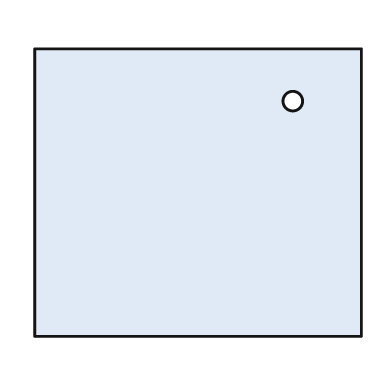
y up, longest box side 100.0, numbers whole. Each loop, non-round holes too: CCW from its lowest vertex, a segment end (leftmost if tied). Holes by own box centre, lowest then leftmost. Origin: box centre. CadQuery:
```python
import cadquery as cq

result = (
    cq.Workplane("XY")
    .moveTo(-50.0, -44.0)
    .lineTo(50.0, -44.0)
    .lineTo(50.0, 44.0)
    .lineTo(-50.0, 44.0)
    .close()
    .moveTo(29.0, 28.0)
    .circle(3.0)
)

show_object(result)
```